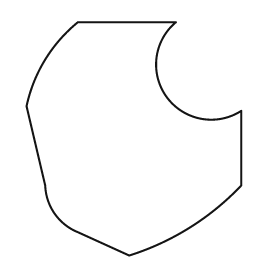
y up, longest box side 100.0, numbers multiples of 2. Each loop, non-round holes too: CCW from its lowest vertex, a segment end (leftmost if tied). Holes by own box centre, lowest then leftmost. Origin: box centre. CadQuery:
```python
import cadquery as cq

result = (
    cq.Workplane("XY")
    .moveTo(-2.0, -50.0)
    .threePointArc((24.0, -38.0), (46.0, -20.0))
    .lineTo(46.0, 12.0)
    .threePointArc((14.0, 18.0), (18.0, 50.0))
    .lineTo(-24.0, 50.0)
    .threePointArc((-38.0, 34.0), (-46.0, 14.0))
    .lineTo(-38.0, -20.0)
    .threePointArc((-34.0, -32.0), (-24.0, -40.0))
    .close()
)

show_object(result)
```